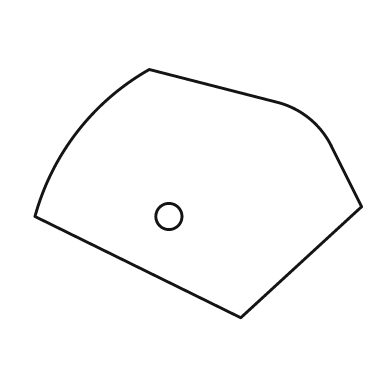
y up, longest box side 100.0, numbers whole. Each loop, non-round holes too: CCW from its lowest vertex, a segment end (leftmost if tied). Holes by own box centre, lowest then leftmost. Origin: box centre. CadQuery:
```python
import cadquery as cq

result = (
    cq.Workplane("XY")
    .moveTo(13.0, -38.0)
    .lineTo(50.0, -4.0)
    .lineTo(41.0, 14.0)
    .threePointArc((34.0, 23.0), (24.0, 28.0))
    .lineTo(-15.0, 38.0)
    .threePointArc((-37.0, 19.0), (-50.0, -7.0))
    .close()
    .moveTo(-9.0, -7.0)
    .circle(4.0)
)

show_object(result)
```